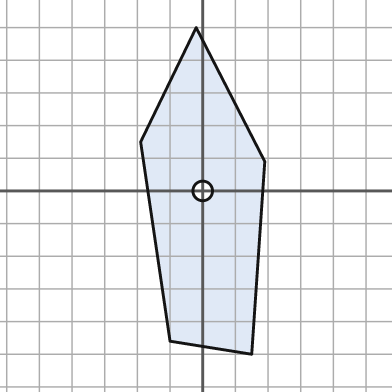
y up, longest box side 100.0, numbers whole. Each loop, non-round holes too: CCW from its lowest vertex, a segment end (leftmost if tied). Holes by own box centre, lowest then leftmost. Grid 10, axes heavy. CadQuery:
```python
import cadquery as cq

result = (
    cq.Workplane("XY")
    .moveTo(15.0, -50.0)
    .lineTo(19.0, 9.0)
    .lineTo(-2.0, 50.0)
    .lineTo(-19.0, 15.0)
    .lineTo(-10.0, -46.0)
    .close()
    .moveTo(0.0, 0.0)
    .circle(3.0)
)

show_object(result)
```